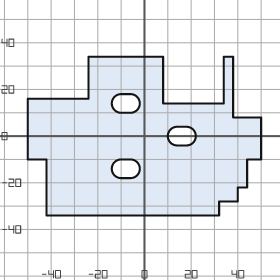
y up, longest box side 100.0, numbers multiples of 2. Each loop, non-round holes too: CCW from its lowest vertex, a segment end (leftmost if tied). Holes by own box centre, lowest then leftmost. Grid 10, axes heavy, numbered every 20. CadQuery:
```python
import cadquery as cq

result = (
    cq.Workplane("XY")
    .moveTo(-42.0, -34.0)
    .lineTo(32.0, -34.0)
    .lineTo(32.0, -28.0)
    .lineTo(40.0, -28.0)
    .lineTo(40.0, -22.0)
    .lineTo(44.0, -22.0)
    .lineTo(44.0, -10.0)
    .lineTo(50.0, -10.0)
    .lineTo(50.0, 8.0)
    .lineTo(38.0, 8.0)
    .lineTo(38.0, 34.0)
    .lineTo(34.0, 34.0)
    .lineTo(34.0, 14.0)
    .lineTo(8.0, 14.0)
    .lineTo(8.0, 34.0)
    .lineTo(-24.0, 34.0)
    .lineTo(-24.0, 16.0)
    .lineTo(-50.0, 16.0)
    .lineTo(-50.0, -10.0)
    .lineTo(-42.0, -10.0)
    .close()
    .moveTo(-10.0, -18.0)
    .lineTo(-6.0, -18.0)
    .threePointArc((-2.0, -14.0), (-6.0, -10.0))
    .lineTo(-10.0, -10.0)
    .threePointArc((-14.0, -14.0), (-10.0, -18.0))
    .close()
    .moveTo(14.0, -4.0)
    .lineTo(18.0, -4.0)
    .threePointArc((22.0, 0.0), (18.0, 4.0))
    .lineTo(14.0, 4.0)
    .threePointArc((10.0, 0.0), (14.0, -4.0))
    .close()
    .moveTo(-10.0, 10.0)
    .lineTo(-6.0, 10.0)
    .threePointArc((-2.0, 14.0), (-6.0, 18.0))
    .lineTo(-10.0, 18.0)
    .threePointArc((-14.0, 14.0), (-10.0, 10.0))
    .close()
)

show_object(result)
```